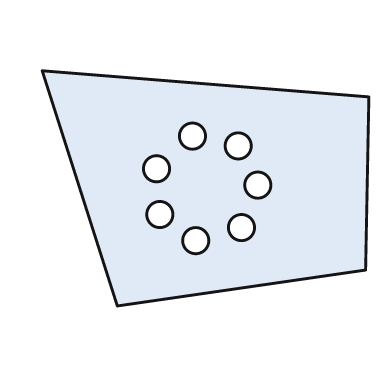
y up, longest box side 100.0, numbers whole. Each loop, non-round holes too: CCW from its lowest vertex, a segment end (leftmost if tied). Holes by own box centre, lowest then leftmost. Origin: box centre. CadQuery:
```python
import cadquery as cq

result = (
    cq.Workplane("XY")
    .moveTo(-27.0, -36.0)
    .lineTo(49.0, -25.0)
    .lineTo(50.0, 28.0)
    .lineTo(-50.0, 36.0)
    .close()
    .moveTo(-3.0, -16.0)
    .circle(4.0)
    .moveTo(11.0, -12.0)
    .circle(4.0)
    .moveTo(-14.0, -8.0)
    .circle(4.0)
    .moveTo(16.0, 1.0)
    .circle(4.0)
    .moveTo(-15.0, 6.0)
    .circle(4.0)
    .moveTo(10.0, 13.0)
    .circle(4.0)
    .moveTo(-4.0, 16.0)
    .circle(4.0)
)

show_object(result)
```